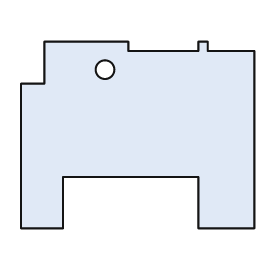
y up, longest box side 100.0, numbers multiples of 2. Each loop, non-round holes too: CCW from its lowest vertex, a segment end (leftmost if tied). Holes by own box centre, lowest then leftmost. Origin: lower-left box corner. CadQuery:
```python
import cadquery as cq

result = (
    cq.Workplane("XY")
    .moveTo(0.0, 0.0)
    .lineTo(18.0, 0.0)
    .lineTo(18.0, 22.0)
    .lineTo(76.0, 22.0)
    .lineTo(76.0, 0.0)
    .lineTo(100.0, 0.0)
    .lineTo(100.0, 76.0)
    .lineTo(80.0, 76.0)
    .lineTo(80.0, 80.0)
    .lineTo(76.0, 80.0)
    .lineTo(76.0, 76.0)
    .lineTo(46.0, 76.0)
    .lineTo(46.0, 80.0)
    .lineTo(10.0, 80.0)
    .lineTo(10.0, 62.0)
    .lineTo(0.0, 62.0)
    .close()
    .moveTo(36.0, 68.0)
    .circle(4.0)
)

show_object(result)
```